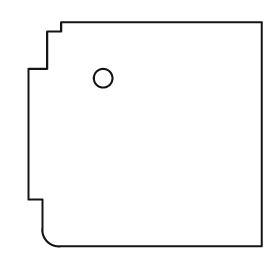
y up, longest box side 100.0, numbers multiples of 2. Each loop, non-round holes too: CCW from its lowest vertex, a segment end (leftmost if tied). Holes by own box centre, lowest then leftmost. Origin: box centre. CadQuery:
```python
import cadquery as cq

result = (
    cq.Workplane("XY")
    .moveTo(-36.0, -48.0)
    .lineTo(50.0, -48.0)
    .lineTo(50.0, 48.0)
    .lineTo(-36.0, 48.0)
    .lineTo(-36.0, 44.0)
    .lineTo(-42.0, 44.0)
    .lineTo(-42.0, 28.0)
    .lineTo(-50.0, 28.0)
    .lineTo(-50.0, -28.0)
    .lineTo(-44.0, -28.0)
    .lineTo(-44.0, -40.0)
    .threePointArc((-42.0, -46.0), (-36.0, -48.0))
    .close()
    .moveTo(-18.0, 24.0)
    .circle(4.0)
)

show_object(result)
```